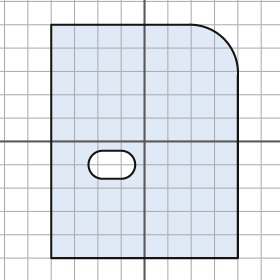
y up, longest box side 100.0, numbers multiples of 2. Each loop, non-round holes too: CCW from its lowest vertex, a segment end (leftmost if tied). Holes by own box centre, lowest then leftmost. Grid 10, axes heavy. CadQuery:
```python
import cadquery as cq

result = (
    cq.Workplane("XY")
    .moveTo(-40.0, -50.0)
    .lineTo(40.0, -50.0)
    .lineTo(40.0, 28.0)
    .threePointArc((34.0, 44.0), (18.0, 50.0))
    .lineTo(-40.0, 50.0)
    .close()
    .moveTo(-18.0, -16.0)
    .lineTo(-10.0, -16.0)
    .threePointArc((-4.0, -10.0), (-10.0, -4.0))
    .lineTo(-18.0, -4.0)
    .threePointArc((-24.0, -10.0), (-18.0, -16.0))
    .close()
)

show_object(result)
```